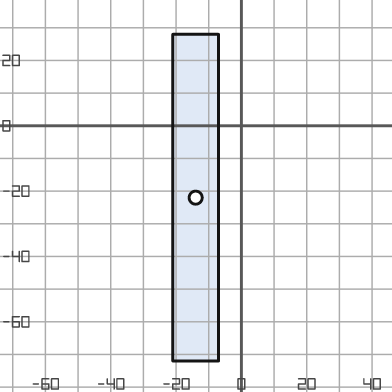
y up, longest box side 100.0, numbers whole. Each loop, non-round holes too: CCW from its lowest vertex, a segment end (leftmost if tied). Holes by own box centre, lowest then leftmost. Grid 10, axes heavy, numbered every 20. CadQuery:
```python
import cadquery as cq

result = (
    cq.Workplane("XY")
    .moveTo(-21.0, -72.0)
    .lineTo(-7.0, -72.0)
    .lineTo(-7.0, 28.0)
    .lineTo(-21.0, 28.0)
    .close()
    .moveTo(-14.0, -22.0)
    .circle(2.0)
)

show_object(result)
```